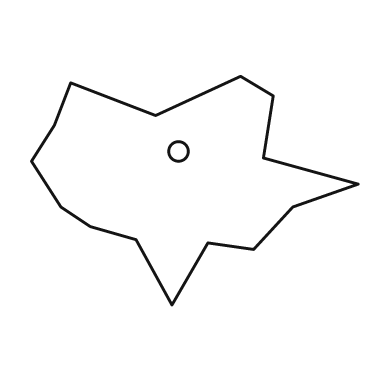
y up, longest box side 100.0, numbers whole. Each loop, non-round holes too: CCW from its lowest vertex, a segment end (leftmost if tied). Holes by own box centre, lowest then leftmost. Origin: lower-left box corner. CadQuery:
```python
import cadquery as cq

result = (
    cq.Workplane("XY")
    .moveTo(43.0, 0.0)
    .lineTo(54.0, 19.0)
    .lineTo(68.0, 17.0)
    .lineTo(80.0, 30.0)
    .lineTo(100.0, 37.0)
    .lineTo(71.0, 45.0)
    .lineTo(74.0, 64.0)
    .lineTo(64.0, 70.0)
    .lineTo(38.0, 58.0)
    .lineTo(12.0, 68.0)
    .lineTo(7.0, 55.0)
    .lineTo(0.0, 44.0)
    .lineTo(9.0, 30.0)
    .lineTo(18.0, 24.0)
    .lineTo(32.0, 20.0)
    .close()
    .moveTo(45.0, 47.0)
    .circle(3.0)
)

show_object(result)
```